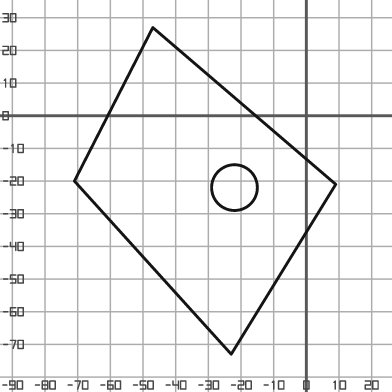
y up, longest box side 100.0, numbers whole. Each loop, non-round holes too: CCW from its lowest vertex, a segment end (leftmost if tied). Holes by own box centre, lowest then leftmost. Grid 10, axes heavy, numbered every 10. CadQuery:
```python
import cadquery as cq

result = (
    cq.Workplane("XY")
    .moveTo(-23.0, -73.0)
    .lineTo(9.0, -21.0)
    .lineTo(-47.0, 27.0)
    .lineTo(-71.0, -20.0)
    .close()
    .moveTo(-22.0, -22.0)
    .circle(7.0)
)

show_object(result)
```